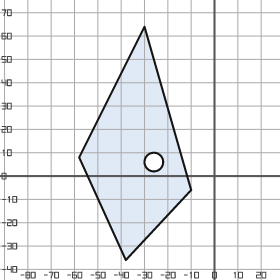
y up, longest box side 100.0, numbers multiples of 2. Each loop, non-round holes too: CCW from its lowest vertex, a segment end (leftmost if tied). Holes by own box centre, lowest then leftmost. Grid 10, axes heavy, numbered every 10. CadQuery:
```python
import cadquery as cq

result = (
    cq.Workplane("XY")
    .moveTo(-38.0, -36.0)
    .lineTo(-10.0, -6.0)
    .lineTo(-30.0, 64.0)
    .lineTo(-58.0, 8.0)
    .close()
    .moveTo(-26.0, 6.0)
    .circle(4.0)
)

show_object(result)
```